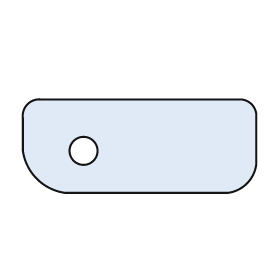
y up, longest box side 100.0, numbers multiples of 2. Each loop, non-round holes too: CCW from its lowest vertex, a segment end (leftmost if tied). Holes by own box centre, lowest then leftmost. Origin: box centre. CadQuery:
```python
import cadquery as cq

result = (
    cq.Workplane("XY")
    .moveTo(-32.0, -20.0)
    .lineTo(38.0, -20.0)
    .threePointArc((46.0, -16.0), (50.0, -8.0))
    .lineTo(50.0, 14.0)
    .threePointArc((48.0, 18.0), (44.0, 20.0))
    .lineTo(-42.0, 20.0)
    .threePointArc((-48.0, 18.0), (-50.0, 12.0))
    .lineTo(-50.0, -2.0)
    .threePointArc((-44.0, -14.0), (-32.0, -20.0))
    .close()
    .moveTo(-24.0, -2.0)
    .circle(6.0)
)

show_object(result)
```